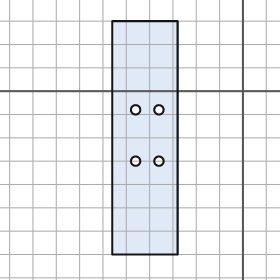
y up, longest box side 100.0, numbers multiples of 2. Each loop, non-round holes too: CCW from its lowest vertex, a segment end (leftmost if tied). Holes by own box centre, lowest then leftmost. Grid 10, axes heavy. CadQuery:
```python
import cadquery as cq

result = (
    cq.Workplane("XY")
    .moveTo(-56.0, -70.0)
    .lineTo(-28.0, -70.0)
    .lineTo(-28.0, 30.0)
    .lineTo(-56.0, 30.0)
    .close()
    .moveTo(-46.0, -30.0)
    .circle(2.0)
    .moveTo(-36.0, -30.0)
    .circle(2.0)
    .moveTo(-46.0, -8.0)
    .circle(2.0)
    .moveTo(-36.0, -8.0)
    .circle(2.0)
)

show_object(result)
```